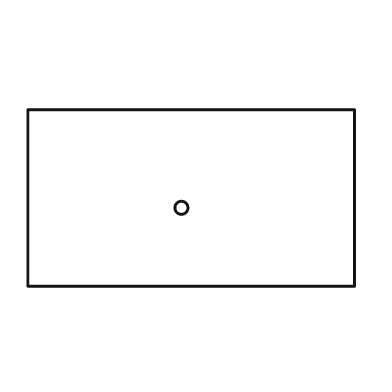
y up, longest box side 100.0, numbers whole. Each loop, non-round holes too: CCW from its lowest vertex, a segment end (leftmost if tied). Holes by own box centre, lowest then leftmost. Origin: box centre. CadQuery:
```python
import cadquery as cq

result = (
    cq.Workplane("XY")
    .moveTo(-50.0, -27.0)
    .lineTo(50.0, -27.0)
    .lineTo(50.0, 27.0)
    .lineTo(-50.0, 27.0)
    .close()
    .moveTo(-3.0, -3.0)
    .circle(2.0)
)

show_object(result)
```